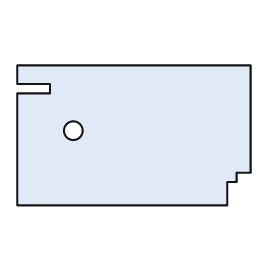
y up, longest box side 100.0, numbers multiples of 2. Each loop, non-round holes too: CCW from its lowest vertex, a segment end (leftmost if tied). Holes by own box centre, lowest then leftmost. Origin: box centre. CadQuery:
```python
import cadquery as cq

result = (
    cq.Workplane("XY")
    .moveTo(-50.0, -30.0)
    .lineTo(40.0, -30.0)
    .lineTo(40.0, -20.0)
    .lineTo(44.0, -20.0)
    .lineTo(44.0, -16.0)
    .lineTo(50.0, -16.0)
    .lineTo(50.0, 30.0)
    .lineTo(-50.0, 30.0)
    .lineTo(-50.0, 22.0)
    .lineTo(-36.0, 22.0)
    .lineTo(-36.0, 18.0)
    .lineTo(-50.0, 18.0)
    .close()
    .moveTo(-26.0, 2.0)
    .circle(4.0)
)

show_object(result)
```